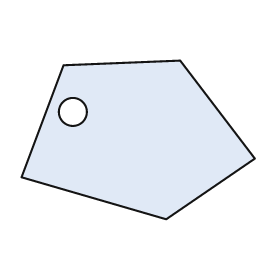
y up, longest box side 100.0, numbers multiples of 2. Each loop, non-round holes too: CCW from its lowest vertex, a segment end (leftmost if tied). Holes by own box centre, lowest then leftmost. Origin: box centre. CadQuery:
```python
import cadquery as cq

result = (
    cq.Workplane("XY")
    .moveTo(12.0, -34.0)
    .lineTo(50.0, -8.0)
    .lineTo(18.0, 34.0)
    .lineTo(-32.0, 32.0)
    .lineTo(-50.0, -16.0)
    .close()
    .moveTo(-28.0, 12.0)
    .circle(6.0)
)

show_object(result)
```